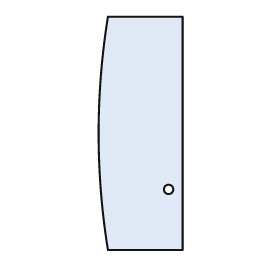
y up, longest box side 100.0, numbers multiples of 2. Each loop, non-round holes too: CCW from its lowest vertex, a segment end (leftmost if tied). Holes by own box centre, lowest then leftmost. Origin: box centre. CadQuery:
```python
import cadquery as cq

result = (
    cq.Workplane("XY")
    .moveTo(-14.0, -50.0)
    .lineTo(18.0, -50.0)
    .lineTo(18.0, 50.0)
    .lineTo(-14.0, 50.0)
    .threePointArc((-18.0, 0.0), (-14.0, -50.0))
    .close()
    .moveTo(12.0, -24.0)
    .circle(2.0)
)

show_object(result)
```